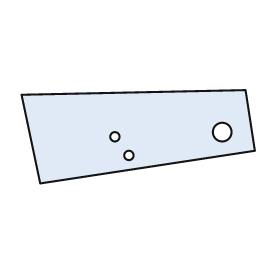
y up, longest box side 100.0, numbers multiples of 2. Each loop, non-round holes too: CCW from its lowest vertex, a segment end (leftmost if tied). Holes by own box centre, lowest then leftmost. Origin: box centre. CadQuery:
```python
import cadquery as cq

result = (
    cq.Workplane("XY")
    .moveTo(-42.0, -20.0)
    .lineTo(50.0, -6.0)
    .lineTo(46.0, 20.0)
    .lineTo(-50.0, 18.0)
    .close()
    .moveTo(-4.0, -8.0)
    .circle(2.0)
    .moveTo(-10.0, 0.0)
    .circle(2.0)
    .moveTo(36.0, 2.0)
    .circle(4.0)
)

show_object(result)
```